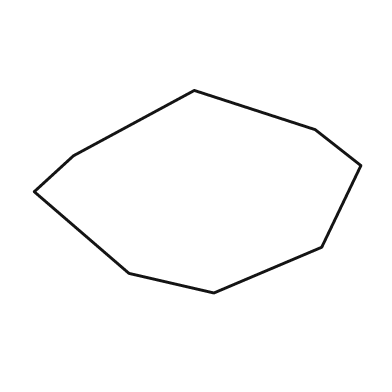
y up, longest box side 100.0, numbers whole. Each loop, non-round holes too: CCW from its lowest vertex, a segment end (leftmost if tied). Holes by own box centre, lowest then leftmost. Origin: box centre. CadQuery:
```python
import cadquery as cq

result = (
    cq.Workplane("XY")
    .moveTo(5.0, -31.0)
    .lineTo(38.0, -17.0)
    .lineTo(50.0, 8.0)
    .lineTo(36.0, 19.0)
    .lineTo(-1.0, 31.0)
    .lineTo(-38.0, 11.0)
    .lineTo(-50.0, 0.0)
    .lineTo(-21.0, -25.0)
    .close()
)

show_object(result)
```